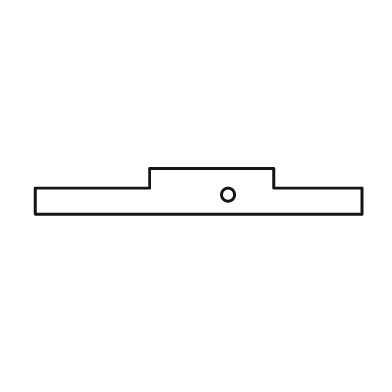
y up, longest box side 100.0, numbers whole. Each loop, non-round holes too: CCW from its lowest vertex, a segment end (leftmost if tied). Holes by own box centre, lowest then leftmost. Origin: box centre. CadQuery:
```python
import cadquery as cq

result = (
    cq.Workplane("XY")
    .moveTo(-50.0, -7.0)
    .lineTo(50.0, -7.0)
    .lineTo(50.0, 1.0)
    .lineTo(23.0, 1.0)
    .lineTo(23.0, 7.0)
    .lineTo(-15.0, 7.0)
    .lineTo(-15.0, 1.0)
    .lineTo(-50.0, 1.0)
    .close()
    .moveTo(9.0, -1.0)
    .circle(2.0)
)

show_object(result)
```